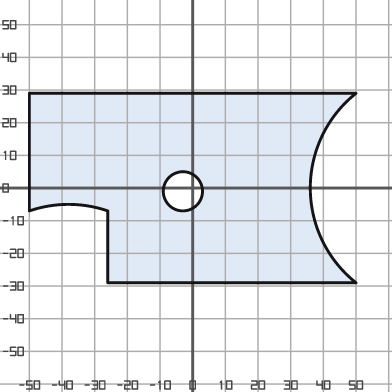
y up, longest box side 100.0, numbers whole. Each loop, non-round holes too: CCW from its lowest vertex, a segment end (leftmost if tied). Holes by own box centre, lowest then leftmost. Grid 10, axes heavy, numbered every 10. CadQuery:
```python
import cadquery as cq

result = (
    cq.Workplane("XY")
    .moveTo(-26.0, -29.0)
    .lineTo(50.0, -29.0)
    .threePointArc((36.0, 0.0), (50.0, 29.0))
    .lineTo(-50.0, 29.0)
    .lineTo(-50.0, -7.0)
    .threePointArc((-38.0, -5.0), (-26.0, -7.0))
    .close()
    .moveTo(-3.0, -1.0)
    .circle(6.0)
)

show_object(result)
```